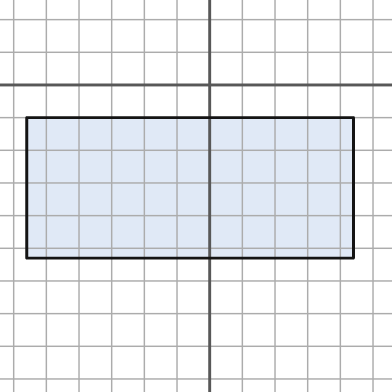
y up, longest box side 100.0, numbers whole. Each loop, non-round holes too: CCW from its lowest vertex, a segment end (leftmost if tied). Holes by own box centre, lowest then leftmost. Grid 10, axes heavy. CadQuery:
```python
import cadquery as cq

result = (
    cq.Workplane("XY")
    .moveTo(-56.0, -53.0)
    .lineTo(44.0, -53.0)
    .lineTo(44.0, -10.0)
    .lineTo(-56.0, -10.0)
    .close()
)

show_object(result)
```